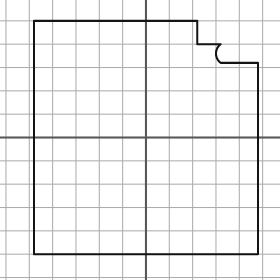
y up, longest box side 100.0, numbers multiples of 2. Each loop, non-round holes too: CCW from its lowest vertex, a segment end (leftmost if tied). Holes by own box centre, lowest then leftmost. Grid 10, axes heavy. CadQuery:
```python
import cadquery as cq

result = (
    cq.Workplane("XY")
    .moveTo(-48.0, -50.0)
    .lineTo(48.0, -50.0)
    .lineTo(48.0, 32.0)
    .lineTo(32.0, 32.0)
    .threePointArc((30.0, 36.0), (32.0, 40.0))
    .lineTo(22.0, 40.0)
    .lineTo(22.0, 50.0)
    .lineTo(-48.0, 50.0)
    .close()
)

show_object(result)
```